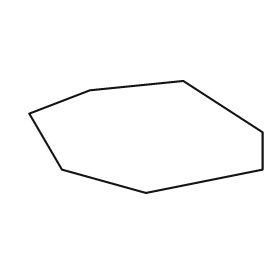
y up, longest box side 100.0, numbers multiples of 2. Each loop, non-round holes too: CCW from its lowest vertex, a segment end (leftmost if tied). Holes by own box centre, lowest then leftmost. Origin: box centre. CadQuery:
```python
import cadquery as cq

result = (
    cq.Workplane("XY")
    .moveTo(0.0, -24.0)
    .lineTo(50.0, -14.0)
    .lineTo(50.0, 2.0)
    .lineTo(16.0, 24.0)
    .lineTo(-24.0, 20.0)
    .lineTo(-50.0, 10.0)
    .lineTo(-36.0, -14.0)
    .close()
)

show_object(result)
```